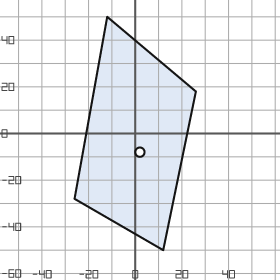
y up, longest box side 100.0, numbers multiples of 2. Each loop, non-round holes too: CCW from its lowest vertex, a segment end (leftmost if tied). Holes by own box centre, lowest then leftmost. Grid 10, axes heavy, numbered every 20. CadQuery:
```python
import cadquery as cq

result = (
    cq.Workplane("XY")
    .moveTo(12.0, -50.0)
    .lineTo(26.0, 18.0)
    .lineTo(-12.0, 50.0)
    .lineTo(-26.0, -28.0)
    .close()
    .moveTo(2.0, -8.0)
    .circle(2.0)
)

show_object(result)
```